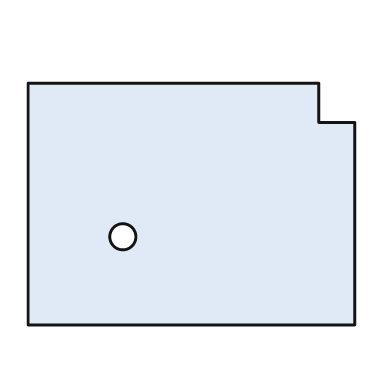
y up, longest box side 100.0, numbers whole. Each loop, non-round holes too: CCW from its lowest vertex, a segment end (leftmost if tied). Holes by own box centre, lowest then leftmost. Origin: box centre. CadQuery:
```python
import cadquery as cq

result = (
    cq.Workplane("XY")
    .moveTo(-50.0, -37.0)
    .lineTo(50.0, -37.0)
    .lineTo(50.0, 25.0)
    .lineTo(39.0, 25.0)
    .lineTo(39.0, 37.0)
    .lineTo(-50.0, 37.0)
    .close()
    .moveTo(-21.0, -10.0)
    .circle(4.0)
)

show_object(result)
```